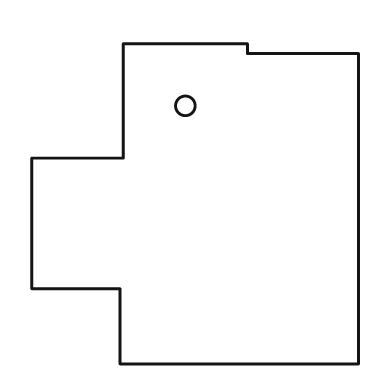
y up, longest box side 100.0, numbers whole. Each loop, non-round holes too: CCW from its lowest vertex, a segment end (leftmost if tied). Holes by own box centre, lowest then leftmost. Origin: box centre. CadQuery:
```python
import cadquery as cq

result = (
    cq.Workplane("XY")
    .moveTo(-23.0, -49.0)
    .lineTo(50.0, -49.0)
    .lineTo(50.0, 46.0)
    .lineTo(16.0, 46.0)
    .lineTo(16.0, 49.0)
    .lineTo(-22.0, 49.0)
    .lineTo(-22.0, 14.0)
    .lineTo(-50.0, 14.0)
    .lineTo(-50.0, -26.0)
    .lineTo(-23.0, -26.0)
    .close()
    .moveTo(-3.0, 30.0)
    .circle(3.0)
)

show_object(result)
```